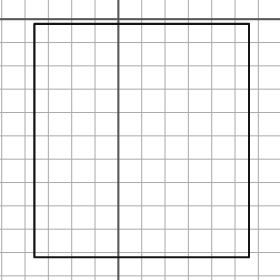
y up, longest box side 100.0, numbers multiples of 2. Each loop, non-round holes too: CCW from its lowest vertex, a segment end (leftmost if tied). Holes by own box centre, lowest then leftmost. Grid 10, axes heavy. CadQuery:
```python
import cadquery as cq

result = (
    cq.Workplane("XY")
    .moveTo(-36.0, -102.0)
    .lineTo(56.0, -102.0)
    .lineTo(56.0, -2.0)
    .lineTo(-36.0, -2.0)
    .close()
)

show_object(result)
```